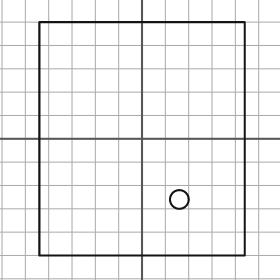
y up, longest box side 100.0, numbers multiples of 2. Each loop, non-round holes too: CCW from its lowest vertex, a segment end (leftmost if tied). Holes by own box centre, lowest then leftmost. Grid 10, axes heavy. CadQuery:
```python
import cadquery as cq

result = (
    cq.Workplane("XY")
    .moveTo(-44.0, -50.0)
    .lineTo(44.0, -50.0)
    .lineTo(44.0, 50.0)
    .lineTo(-44.0, 50.0)
    .close()
    .moveTo(16.0, -26.0)
    .circle(4.0)
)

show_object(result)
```